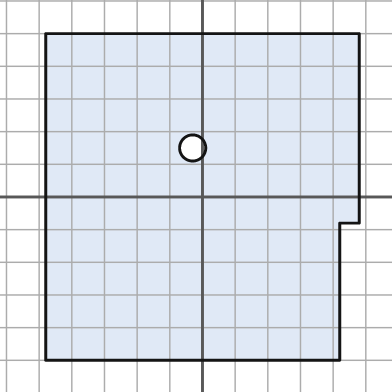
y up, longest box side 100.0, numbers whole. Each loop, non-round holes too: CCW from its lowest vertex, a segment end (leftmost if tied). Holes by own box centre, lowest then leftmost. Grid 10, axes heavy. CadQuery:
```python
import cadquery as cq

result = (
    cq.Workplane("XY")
    .moveTo(-48.0, -50.0)
    .lineTo(42.0, -50.0)
    .lineTo(42.0, -8.0)
    .lineTo(48.0, -8.0)
    .lineTo(48.0, 50.0)
    .lineTo(-48.0, 50.0)
    .close()
    .moveTo(-3.0, 15.0)
    .circle(4.0)
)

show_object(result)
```